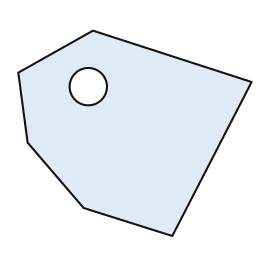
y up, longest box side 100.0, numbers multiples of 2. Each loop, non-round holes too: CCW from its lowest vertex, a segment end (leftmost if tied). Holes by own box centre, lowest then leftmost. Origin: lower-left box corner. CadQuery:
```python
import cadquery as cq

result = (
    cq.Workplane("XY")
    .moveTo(66.0, 0.0)
    .lineTo(100.0, 66.0)
    .lineTo(32.0, 88.0)
    .lineTo(0.0, 70.0)
    .lineTo(4.0, 40.0)
    .lineTo(28.0, 12.0)
    .close()
    .moveTo(30.0, 64.0)
    .circle(8.0)
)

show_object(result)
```